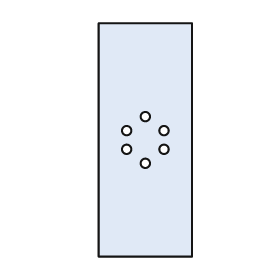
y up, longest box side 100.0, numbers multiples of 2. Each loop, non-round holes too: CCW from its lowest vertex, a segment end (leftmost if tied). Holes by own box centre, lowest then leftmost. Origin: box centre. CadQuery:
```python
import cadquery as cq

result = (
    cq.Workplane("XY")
    .moveTo(-20.0, -50.0)
    .lineTo(20.0, -50.0)
    .lineTo(20.0, 50.0)
    .lineTo(-20.0, 50.0)
    .close()
    .moveTo(0.0, -10.0)
    .circle(2.0)
    .moveTo(-8.0, -4.0)
    .circle(2.0)
    .moveTo(8.0, -4.0)
    .circle(2.0)
    .moveTo(-8.0, 4.0)
    .circle(2.0)
    .moveTo(8.0, 4.0)
    .circle(2.0)
    .moveTo(0.0, 10.0)
    .circle(2.0)
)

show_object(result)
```